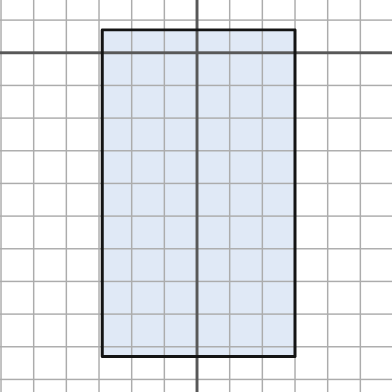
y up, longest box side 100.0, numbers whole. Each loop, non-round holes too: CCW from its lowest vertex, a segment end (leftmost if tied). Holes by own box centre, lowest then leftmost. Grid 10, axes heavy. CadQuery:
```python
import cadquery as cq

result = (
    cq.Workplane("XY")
    .moveTo(-29.0, -93.0)
    .lineTo(30.0, -93.0)
    .lineTo(30.0, 7.0)
    .lineTo(-29.0, 7.0)
    .close()
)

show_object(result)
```